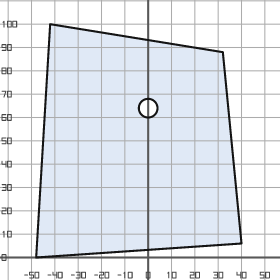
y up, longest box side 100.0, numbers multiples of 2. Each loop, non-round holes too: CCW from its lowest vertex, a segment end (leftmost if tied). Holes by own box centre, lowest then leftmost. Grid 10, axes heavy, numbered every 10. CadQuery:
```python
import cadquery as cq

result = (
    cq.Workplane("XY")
    .moveTo(-48.0, 0.0)
    .lineTo(40.0, 6.0)
    .lineTo(32.0, 88.0)
    .lineTo(-42.0, 100.0)
    .close()
    .moveTo(0.0, 64.0)
    .circle(4.0)
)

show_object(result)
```